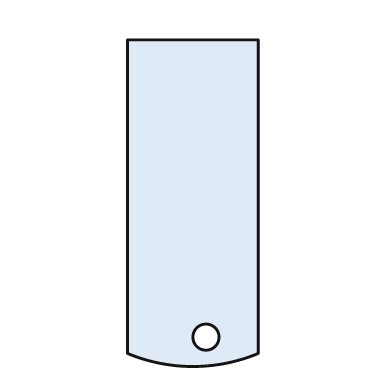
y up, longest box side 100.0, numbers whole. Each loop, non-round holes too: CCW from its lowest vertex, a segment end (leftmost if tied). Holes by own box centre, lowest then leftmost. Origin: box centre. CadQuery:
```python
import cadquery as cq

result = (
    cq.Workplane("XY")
    .moveTo(-20.0, -46.0)
    .threePointArc((0.0, -50.0), (20.0, -46.0))
    .lineTo(20.0, 50.0)
    .lineTo(-20.0, 50.0)
    .close()
    .moveTo(4.0, -41.0)
    .circle(4.0)
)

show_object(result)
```